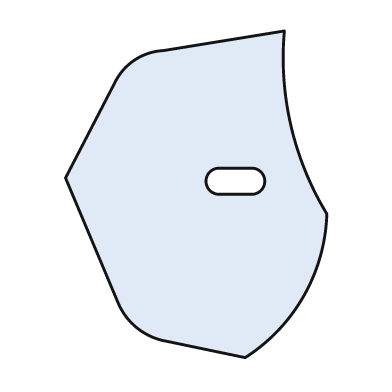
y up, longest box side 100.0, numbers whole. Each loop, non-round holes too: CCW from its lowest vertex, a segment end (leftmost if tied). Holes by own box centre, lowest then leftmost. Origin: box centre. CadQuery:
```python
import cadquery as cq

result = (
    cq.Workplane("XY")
    .moveTo(15.0, -50.0)
    .threePointArc((33.0, -31.0), (40.0, -6.0))
    .threePointArc((29.0, 21.0), (27.0, 50.0))
    .lineTo(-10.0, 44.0)
    .threePointArc((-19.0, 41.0), (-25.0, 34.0))
    .lineTo(-40.0, 5.0)
    .lineTo(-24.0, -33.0)
    .threePointArc((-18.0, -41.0), (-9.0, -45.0))
    .close()
    .moveTo(7.0, 0.0)
    .lineTo(17.0, 0.0)
    .threePointArc((21.0, 4.0), (17.0, 8.0))
    .lineTo(7.0, 8.0)
    .threePointArc((3.0, 4.0), (7.0, 0.0))
    .close()
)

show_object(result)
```